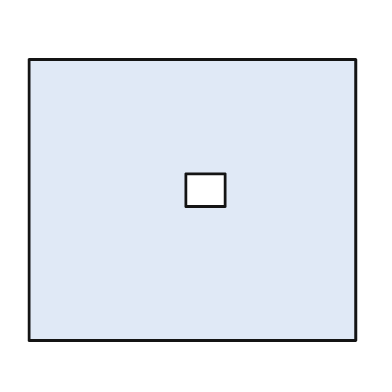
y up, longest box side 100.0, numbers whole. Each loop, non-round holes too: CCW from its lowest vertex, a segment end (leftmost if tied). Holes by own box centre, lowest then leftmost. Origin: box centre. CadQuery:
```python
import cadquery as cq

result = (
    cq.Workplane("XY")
    .moveTo(-50.0, -43.0)
    .lineTo(50.0, -43.0)
    .lineTo(50.0, 43.0)
    .lineTo(-50.0, 43.0)
    .close()
    .moveTo(-2.0, -2.0)
    .lineTo(10.0, -2.0)
    .lineTo(10.0, 8.0)
    .lineTo(-2.0, 8.0)
    .close()
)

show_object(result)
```